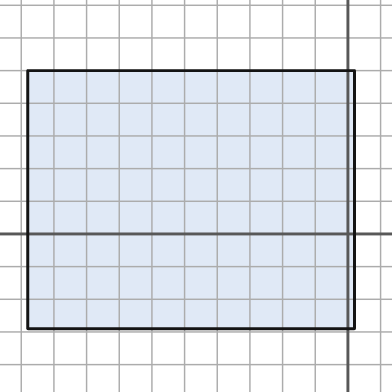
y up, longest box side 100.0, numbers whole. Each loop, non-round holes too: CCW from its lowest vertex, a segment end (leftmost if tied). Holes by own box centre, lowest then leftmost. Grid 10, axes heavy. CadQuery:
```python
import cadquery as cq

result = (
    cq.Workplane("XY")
    .moveTo(-98.0, -29.0)
    .lineTo(2.0, -29.0)
    .lineTo(2.0, 50.0)
    .lineTo(-98.0, 50.0)
    .close()
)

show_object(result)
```